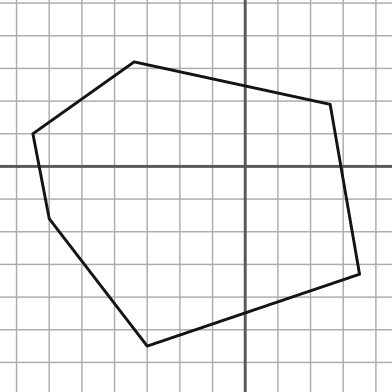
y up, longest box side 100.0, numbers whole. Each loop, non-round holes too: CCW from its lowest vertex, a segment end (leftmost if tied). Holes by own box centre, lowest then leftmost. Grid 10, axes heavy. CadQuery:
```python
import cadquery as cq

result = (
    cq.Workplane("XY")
    .moveTo(-30.0, -55.0)
    .lineTo(35.0, -33.0)
    .lineTo(26.0, 19.0)
    .lineTo(-34.0, 32.0)
    .lineTo(-65.0, 10.0)
    .lineTo(-60.0, -16.0)
    .close()
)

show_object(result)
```